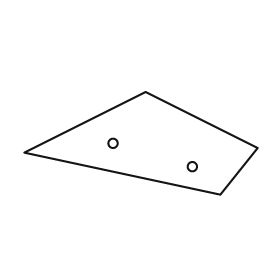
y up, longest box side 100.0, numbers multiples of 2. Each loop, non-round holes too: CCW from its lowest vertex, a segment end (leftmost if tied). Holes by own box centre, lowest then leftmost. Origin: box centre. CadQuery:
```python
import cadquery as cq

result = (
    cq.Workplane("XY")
    .moveTo(34.0, -22.0)
    .lineTo(50.0, -2.0)
    .lineTo(2.0, 22.0)
    .lineTo(-50.0, -4.0)
    .close()
    .moveTo(22.0, -10.0)
    .circle(2.0)
    .moveTo(-12.0, 0.0)
    .circle(2.0)
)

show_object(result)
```